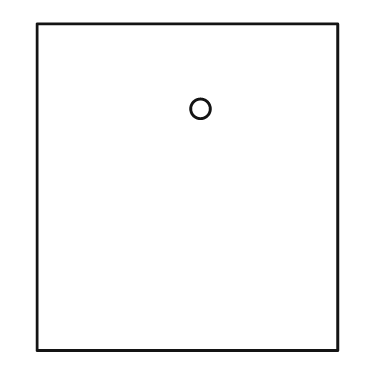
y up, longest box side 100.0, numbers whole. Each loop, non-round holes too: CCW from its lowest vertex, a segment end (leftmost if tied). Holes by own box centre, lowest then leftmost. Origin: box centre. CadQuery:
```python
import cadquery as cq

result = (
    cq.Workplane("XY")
    .moveTo(-46.0, -50.0)
    .lineTo(46.0, -50.0)
    .lineTo(46.0, 50.0)
    .lineTo(-46.0, 50.0)
    .close()
    .moveTo(4.0, 24.0)
    .circle(3.0)
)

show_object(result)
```